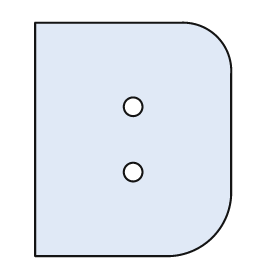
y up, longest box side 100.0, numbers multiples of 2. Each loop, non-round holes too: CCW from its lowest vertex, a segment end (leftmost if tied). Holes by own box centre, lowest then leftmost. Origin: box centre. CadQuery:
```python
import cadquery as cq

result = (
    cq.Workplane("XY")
    .moveTo(-42.0, -50.0)
    .lineTo(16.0, -50.0)
    .threePointArc((34.0, -42.0), (42.0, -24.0))
    .lineTo(42.0, 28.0)
    .threePointArc((36.0, 44.0), (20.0, 50.0))
    .lineTo(-42.0, 50.0)
    .close()
    .moveTo(0.0, -14.0)
    .circle(4.0)
    .moveTo(0.0, 14.0)
    .circle(4.0)
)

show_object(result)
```